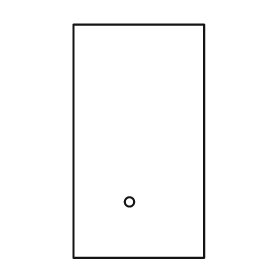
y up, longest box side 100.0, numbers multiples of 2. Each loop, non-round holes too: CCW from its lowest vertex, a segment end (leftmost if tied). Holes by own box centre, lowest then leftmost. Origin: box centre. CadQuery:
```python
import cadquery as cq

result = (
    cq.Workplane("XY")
    .moveTo(-28.0, -50.0)
    .lineTo(28.0, -50.0)
    .lineTo(28.0, 50.0)
    .lineTo(-28.0, 50.0)
    .close()
    .moveTo(-4.0, -26.0)
    .circle(2.0)
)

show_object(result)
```